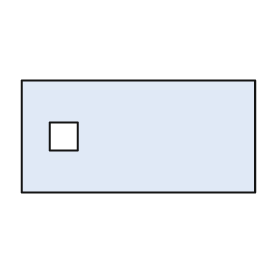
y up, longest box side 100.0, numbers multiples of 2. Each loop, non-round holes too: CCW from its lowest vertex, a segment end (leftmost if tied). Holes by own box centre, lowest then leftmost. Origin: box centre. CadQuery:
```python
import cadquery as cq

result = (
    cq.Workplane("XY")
    .moveTo(-50.0, -24.0)
    .lineTo(50.0, -24.0)
    .lineTo(50.0, 24.0)
    .lineTo(-50.0, 24.0)
    .close()
    .moveTo(-38.0, -6.0)
    .lineTo(-26.0, -6.0)
    .lineTo(-26.0, 6.0)
    .lineTo(-38.0, 6.0)
    .close()
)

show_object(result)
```